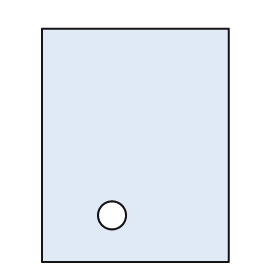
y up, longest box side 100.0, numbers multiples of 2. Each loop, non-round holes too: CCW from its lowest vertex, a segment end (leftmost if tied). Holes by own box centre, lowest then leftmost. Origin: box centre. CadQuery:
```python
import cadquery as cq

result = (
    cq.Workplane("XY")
    .moveTo(-40.0, -50.0)
    .lineTo(40.0, -50.0)
    .lineTo(40.0, 50.0)
    .lineTo(-40.0, 50.0)
    .close()
    .moveTo(-10.0, -30.0)
    .circle(6.0)
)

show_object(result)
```